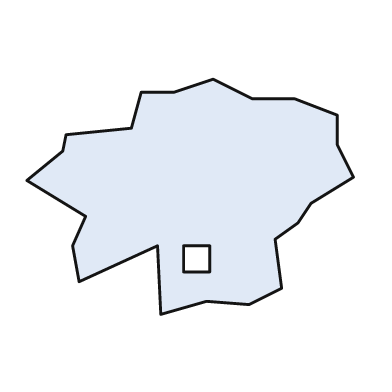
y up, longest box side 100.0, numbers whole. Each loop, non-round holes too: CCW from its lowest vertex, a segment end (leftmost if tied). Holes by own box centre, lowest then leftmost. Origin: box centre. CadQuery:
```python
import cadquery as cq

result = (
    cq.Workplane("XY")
    .moveTo(-9.0, -36.0)
    .lineTo(5.0, -32.0)
    .lineTo(18.0, -33.0)
    .lineTo(28.0, -28.0)
    .lineTo(26.0, -13.0)
    .lineTo(33.0, -8.0)
    .lineTo(37.0, -2.0)
    .lineTo(50.0, 6.0)
    .lineTo(45.0, 16.0)
    .lineTo(45.0, 25.0)
    .lineTo(32.0, 30.0)
    .lineTo(19.0, 30.0)
    .lineTo(7.0, 36.0)
    .lineTo(-5.0, 32.0)
    .lineTo(-15.0, 32.0)
    .lineTo(-18.0, 21.0)
    .lineTo(-38.0, 19.0)
    .lineTo(-39.0, 14.0)
    .lineTo(-50.0, 5.0)
    .lineTo(-32.0, -6.0)
    .lineTo(-36.0, -15.0)
    .lineTo(-34.0, -26.0)
    .lineTo(-10.0, -15.0)
    .close()
    .moveTo(-2.0, -23.0)
    .lineTo(6.0, -23.0)
    .lineTo(6.0, -15.0)
    .lineTo(-2.0, -15.0)
    .close()
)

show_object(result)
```